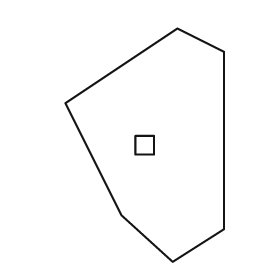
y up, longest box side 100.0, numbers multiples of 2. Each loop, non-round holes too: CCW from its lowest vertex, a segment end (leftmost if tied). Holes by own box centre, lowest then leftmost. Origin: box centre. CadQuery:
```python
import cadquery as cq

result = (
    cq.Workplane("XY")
    .moveTo(12.0, -50.0)
    .lineTo(34.0, -36.0)
    .lineTo(34.0, 40.0)
    .lineTo(14.0, 50.0)
    .lineTo(-34.0, 18.0)
    .lineTo(-10.0, -30.0)
    .close()
    .moveTo(-4.0, -4.0)
    .lineTo(4.0, -4.0)
    .lineTo(4.0, 4.0)
    .lineTo(-4.0, 4.0)
    .close()
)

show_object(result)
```